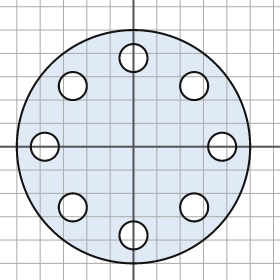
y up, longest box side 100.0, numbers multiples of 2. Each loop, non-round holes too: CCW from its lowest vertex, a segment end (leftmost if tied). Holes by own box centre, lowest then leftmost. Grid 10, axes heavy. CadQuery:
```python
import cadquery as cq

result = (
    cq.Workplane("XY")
    .moveTo(0.0, 0.0)
    .circle(50.0)
    .moveTo(0.0, -38.0)
    .circle(6.0)
    .moveTo(-26.0, -26.0)
    .circle(6.0)
    .moveTo(26.0, -26.0)
    .circle(6.0)
    .moveTo(-38.0, 0.0)
    .circle(6.0)
    .moveTo(38.0, 0.0)
    .circle(6.0)
    .moveTo(-26.0, 26.0)
    .circle(6.0)
    .moveTo(26.0, 26.0)
    .circle(6.0)
    .moveTo(0.0, 38.0)
    .circle(6.0)
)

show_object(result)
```